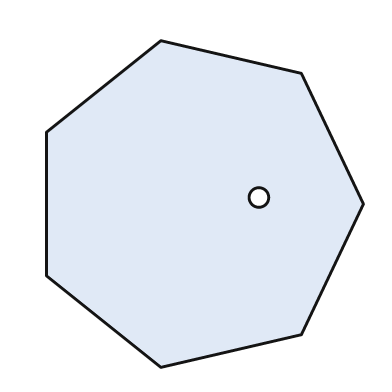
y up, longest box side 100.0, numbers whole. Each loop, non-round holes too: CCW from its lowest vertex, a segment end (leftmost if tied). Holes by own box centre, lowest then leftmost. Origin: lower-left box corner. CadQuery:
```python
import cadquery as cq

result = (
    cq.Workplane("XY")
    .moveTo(35.0, 0.0)
    .lineTo(78.0, 10.0)
    .lineTo(97.0, 50.0)
    .lineTo(78.0, 90.0)
    .lineTo(35.0, 100.0)
    .lineTo(0.0, 72.0)
    .lineTo(0.0, 28.0)
    .close()
    .moveTo(65.0, 52.0)
    .circle(3.0)
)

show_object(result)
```